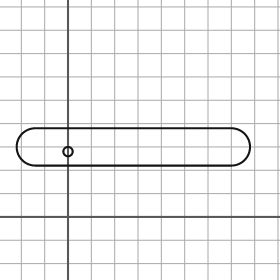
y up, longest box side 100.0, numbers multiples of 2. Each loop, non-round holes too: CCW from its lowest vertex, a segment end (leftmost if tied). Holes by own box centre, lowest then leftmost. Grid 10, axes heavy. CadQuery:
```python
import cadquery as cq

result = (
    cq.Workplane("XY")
    .moveTo(-14.0, 22.0)
    .lineTo(70.0, 22.0)
    .threePointArc((78.0, 30.0), (70.0, 38.0))
    .lineTo(-14.0, 38.0)
    .threePointArc((-22.0, 30.0), (-14.0, 22.0))
    .close()
    .moveTo(0.0, 28.0)
    .circle(2.0)
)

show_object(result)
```